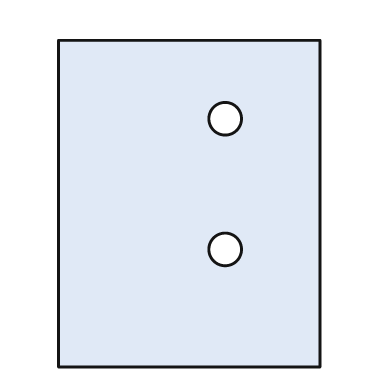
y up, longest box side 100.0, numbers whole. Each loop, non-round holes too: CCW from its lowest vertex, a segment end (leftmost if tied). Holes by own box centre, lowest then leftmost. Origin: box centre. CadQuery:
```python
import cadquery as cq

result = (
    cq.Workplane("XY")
    .moveTo(-40.0, -50.0)
    .lineTo(40.0, -50.0)
    .lineTo(40.0, 50.0)
    .lineTo(-40.0, 50.0)
    .close()
    .moveTo(11.0, -14.0)
    .circle(5.0)
    .moveTo(11.0, 26.0)
    .circle(5.0)
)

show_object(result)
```